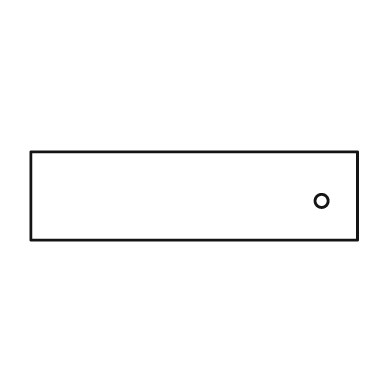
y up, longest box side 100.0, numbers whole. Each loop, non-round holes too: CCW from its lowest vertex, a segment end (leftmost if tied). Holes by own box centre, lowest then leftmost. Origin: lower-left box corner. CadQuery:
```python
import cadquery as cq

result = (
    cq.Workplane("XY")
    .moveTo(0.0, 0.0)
    .lineTo(100.0, 0.0)
    .lineTo(100.0, 27.0)
    .lineTo(0.0, 27.0)
    .close()
    .moveTo(89.0, 12.0)
    .circle(2.0)
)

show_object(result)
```